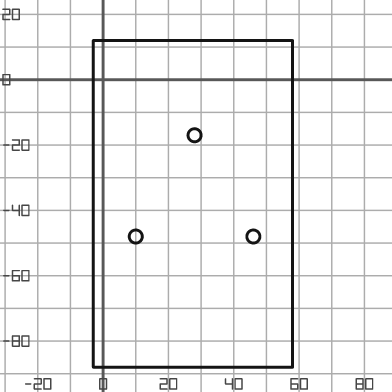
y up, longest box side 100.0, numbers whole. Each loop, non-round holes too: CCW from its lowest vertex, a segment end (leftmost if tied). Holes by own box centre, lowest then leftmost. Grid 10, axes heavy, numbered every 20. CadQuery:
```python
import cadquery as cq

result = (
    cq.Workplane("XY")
    .moveTo(-3.0, -88.0)
    .lineTo(58.0, -88.0)
    .lineTo(58.0, 12.0)
    .lineTo(-3.0, 12.0)
    .close()
    .moveTo(10.0, -48.0)
    .circle(2.0)
    .moveTo(46.0, -48.0)
    .circle(2.0)
    .moveTo(28.0, -17.0)
    .circle(2.0)
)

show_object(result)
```